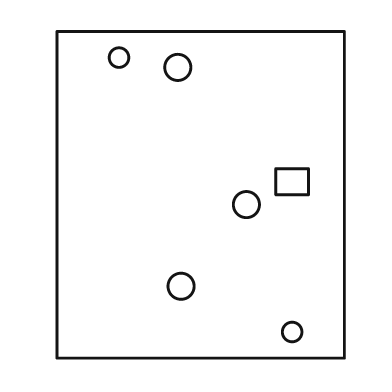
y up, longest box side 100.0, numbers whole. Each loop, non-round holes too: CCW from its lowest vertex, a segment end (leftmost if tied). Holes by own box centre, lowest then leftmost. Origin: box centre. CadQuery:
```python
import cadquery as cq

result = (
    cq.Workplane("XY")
    .moveTo(-44.0, -50.0)
    .lineTo(44.0, -50.0)
    .lineTo(44.0, 50.0)
    .lineTo(-44.0, 50.0)
    .close()
    .moveTo(28.0, -42.0)
    .circle(3.0)
    .moveTo(-6.0, -28.0)
    .circle(4.0)
    .moveTo(14.0, -3.0)
    .circle(4.0)
    .moveTo(23.0, 0.0)
    .lineTo(33.0, 0.0)
    .lineTo(33.0, 8.0)
    .lineTo(23.0, 8.0)
    .close()
    .moveTo(-7.0, 39.0)
    .circle(4.0)
    .moveTo(-25.0, 42.0)
    .circle(3.0)
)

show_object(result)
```